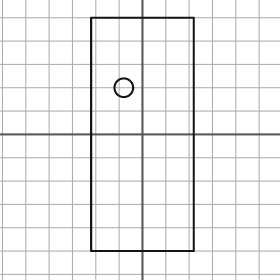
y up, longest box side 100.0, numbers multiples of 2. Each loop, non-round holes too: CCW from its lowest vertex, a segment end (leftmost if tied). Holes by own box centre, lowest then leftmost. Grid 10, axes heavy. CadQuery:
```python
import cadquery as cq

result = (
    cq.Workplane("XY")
    .moveTo(-22.0, -50.0)
    .lineTo(22.0, -50.0)
    .lineTo(22.0, 50.0)
    .lineTo(-22.0, 50.0)
    .close()
    .moveTo(-8.0, 20.0)
    .circle(4.0)
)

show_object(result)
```